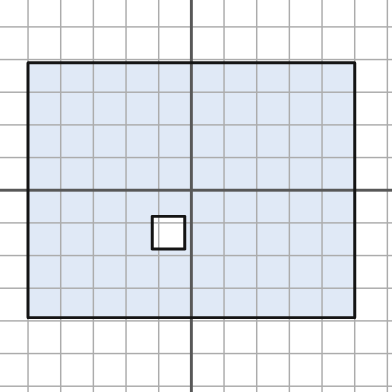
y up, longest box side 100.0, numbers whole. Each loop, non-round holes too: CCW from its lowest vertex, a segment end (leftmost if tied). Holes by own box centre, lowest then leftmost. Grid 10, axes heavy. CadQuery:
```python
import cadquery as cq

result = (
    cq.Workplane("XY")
    .moveTo(-50.0, -39.0)
    .lineTo(50.0, -39.0)
    .lineTo(50.0, 39.0)
    .lineTo(-50.0, 39.0)
    .close()
    .moveTo(-12.0, -18.0)
    .lineTo(-2.0, -18.0)
    .lineTo(-2.0, -8.0)
    .lineTo(-12.0, -8.0)
    .close()
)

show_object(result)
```